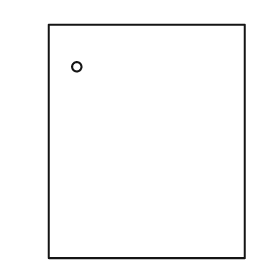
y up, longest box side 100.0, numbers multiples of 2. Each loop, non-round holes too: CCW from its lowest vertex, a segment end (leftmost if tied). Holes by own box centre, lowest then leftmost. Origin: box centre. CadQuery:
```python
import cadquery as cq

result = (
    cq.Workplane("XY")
    .moveTo(-42.0, -50.0)
    .lineTo(42.0, -50.0)
    .lineTo(42.0, 50.0)
    .lineTo(-42.0, 50.0)
    .close()
    .moveTo(-30.0, 32.0)
    .circle(2.0)
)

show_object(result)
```